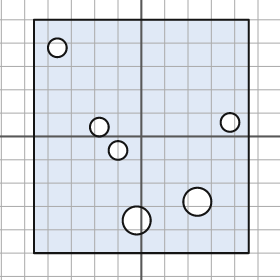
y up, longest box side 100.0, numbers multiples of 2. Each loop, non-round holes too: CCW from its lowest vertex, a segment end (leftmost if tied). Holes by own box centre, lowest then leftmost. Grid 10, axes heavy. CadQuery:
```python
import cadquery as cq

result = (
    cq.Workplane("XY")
    .moveTo(-46.0, -50.0)
    .lineTo(46.0, -50.0)
    .lineTo(46.0, 50.0)
    .lineTo(-46.0, 50.0)
    .close()
    .moveTo(-2.0, -36.0)
    .circle(6.0)
    .moveTo(24.0, -28.0)
    .circle(6.0)
    .moveTo(-10.0, -6.0)
    .circle(4.0)
    .moveTo(-18.0, 4.0)
    .circle(4.0)
    .moveTo(38.0, 6.0)
    .circle(4.0)
    .moveTo(-36.0, 38.0)
    .circle(4.0)
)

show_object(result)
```